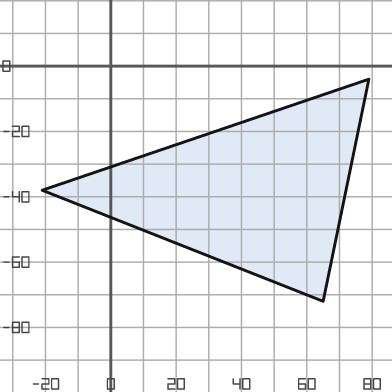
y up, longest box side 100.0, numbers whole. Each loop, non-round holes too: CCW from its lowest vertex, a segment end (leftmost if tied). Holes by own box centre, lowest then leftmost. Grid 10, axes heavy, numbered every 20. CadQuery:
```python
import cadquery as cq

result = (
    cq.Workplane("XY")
    .moveTo(65.0, -72.0)
    .lineTo(79.0, -4.0)
    .lineTo(-21.0, -38.0)
    .close()
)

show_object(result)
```